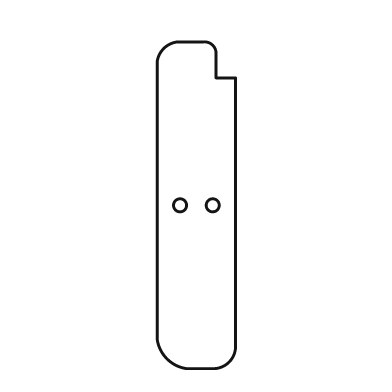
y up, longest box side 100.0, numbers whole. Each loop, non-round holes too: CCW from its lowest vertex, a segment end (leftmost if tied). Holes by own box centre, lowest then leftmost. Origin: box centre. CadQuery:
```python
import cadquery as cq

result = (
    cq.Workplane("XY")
    .moveTo(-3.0, -50.0)
    .lineTo(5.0, -50.0)
    .threePointArc((10.0, -48.0), (12.0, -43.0))
    .lineTo(12.0, 39.0)
    .lineTo(6.0, 39.0)
    .lineTo(6.0, 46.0)
    .threePointArc((5.0, 49.0), (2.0, 50.0))
    .lineTo(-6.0, 50.0)
    .threePointArc((-10.0, 48.0), (-12.0, 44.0))
    .lineTo(-12.0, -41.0)
    .threePointArc((-9.0, -47.0), (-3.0, -50.0))
    .close()
    .moveTo(-5.0, 0.0)
    .circle(2.0)
    .moveTo(5.0, 0.0)
    .circle(2.0)
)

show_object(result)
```